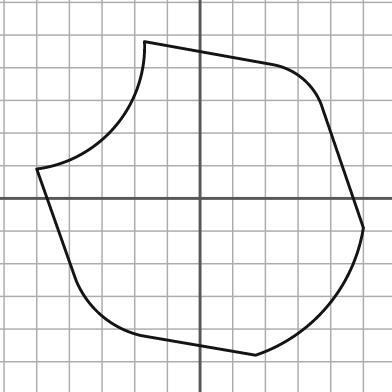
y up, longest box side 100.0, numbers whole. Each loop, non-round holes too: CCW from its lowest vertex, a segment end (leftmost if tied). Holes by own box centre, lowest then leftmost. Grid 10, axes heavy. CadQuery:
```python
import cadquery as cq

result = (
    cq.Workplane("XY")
    .moveTo(17.0, -48.0)
    .threePointArc((39.0, -33.0), (50.0, -9.0))
    .lineTo(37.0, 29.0)
    .threePointArc((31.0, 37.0), (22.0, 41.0))
    .lineTo(-17.0, 48.0)
    .threePointArc((-26.0, 22.0), (-50.0, 9.0))
    .lineTo(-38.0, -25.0)
    .threePointArc((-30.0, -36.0), (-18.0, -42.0))
    .close()
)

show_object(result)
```